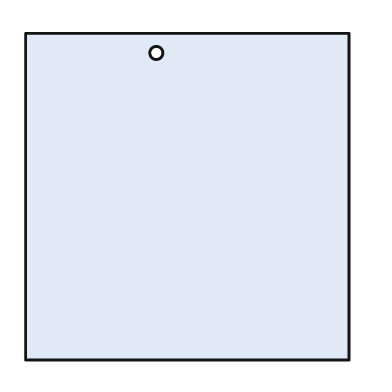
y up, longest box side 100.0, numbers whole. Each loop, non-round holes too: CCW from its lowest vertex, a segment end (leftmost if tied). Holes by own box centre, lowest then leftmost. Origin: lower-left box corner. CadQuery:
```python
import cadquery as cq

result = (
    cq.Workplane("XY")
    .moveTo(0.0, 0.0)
    .lineTo(99.0, 0.0)
    .lineTo(99.0, 100.0)
    .lineTo(0.0, 100.0)
    .close()
    .moveTo(40.0, 94.0)
    .circle(2.0)
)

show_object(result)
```